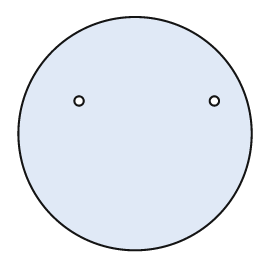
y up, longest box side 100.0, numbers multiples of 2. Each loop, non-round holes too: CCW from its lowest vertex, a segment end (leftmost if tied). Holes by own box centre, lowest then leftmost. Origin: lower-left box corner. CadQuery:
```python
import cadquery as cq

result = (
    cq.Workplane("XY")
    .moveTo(50.0, 50.0)
    .circle(50.0)
    .moveTo(26.0, 64.0)
    .circle(2.0)
    .moveTo(84.0, 64.0)
    .circle(2.0)
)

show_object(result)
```